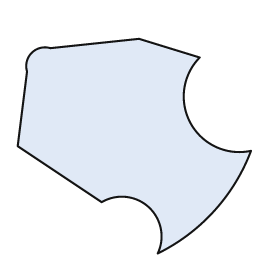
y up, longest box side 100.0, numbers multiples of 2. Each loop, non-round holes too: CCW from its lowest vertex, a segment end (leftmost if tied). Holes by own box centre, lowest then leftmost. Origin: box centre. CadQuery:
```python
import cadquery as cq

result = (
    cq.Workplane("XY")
    .moveTo(10.0, -46.0)
    .threePointArc((34.0, -28.0), (50.0, -2.0))
    .threePointArc((24.0, 10.0), (28.0, 38.0))
    .lineTo(2.0, 46.0)
    .lineTo(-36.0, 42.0)
    .threePointArc((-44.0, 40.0), (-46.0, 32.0))
    .lineTo(-50.0, 0.0)
    .lineTo(-14.0, -24.0)
    .threePointArc((6.0, -26.0), (10.0, -46.0))
    .close()
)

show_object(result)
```